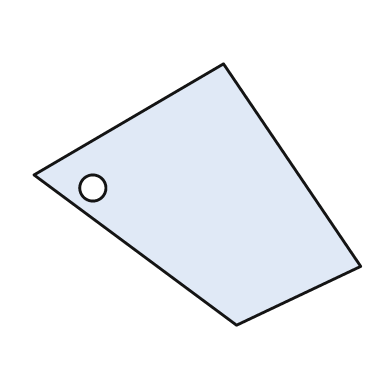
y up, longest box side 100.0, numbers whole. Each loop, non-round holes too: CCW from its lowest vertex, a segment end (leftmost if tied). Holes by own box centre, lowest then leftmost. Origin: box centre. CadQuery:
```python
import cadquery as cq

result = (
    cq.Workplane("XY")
    .moveTo(12.0, -40.0)
    .lineTo(50.0, -22.0)
    .lineTo(8.0, 40.0)
    .lineTo(-50.0, 6.0)
    .close()
    .moveTo(-32.0, 2.0)
    .circle(4.0)
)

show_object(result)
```